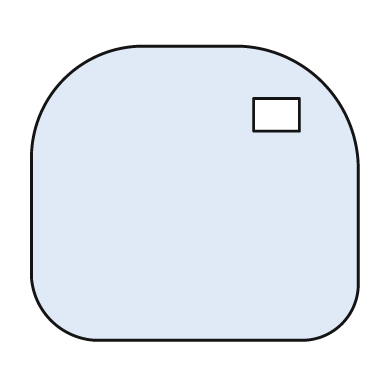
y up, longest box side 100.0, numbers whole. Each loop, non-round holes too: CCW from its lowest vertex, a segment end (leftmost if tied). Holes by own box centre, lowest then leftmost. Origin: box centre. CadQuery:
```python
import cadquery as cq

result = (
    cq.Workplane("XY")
    .moveTo(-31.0, -45.0)
    .lineTo(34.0, -45.0)
    .threePointArc((45.0, -40.0), (50.0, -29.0))
    .lineTo(50.0, 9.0)
    .threePointArc((39.0, 34.0), (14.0, 45.0))
    .lineTo(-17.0, 45.0)
    .threePointArc((-40.0, 35.0), (-50.0, 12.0))
    .lineTo(-50.0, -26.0)
    .threePointArc((-44.0, -39.0), (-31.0, -45.0))
    .close()
    .moveTo(18.0, 19.0)
    .lineTo(32.0, 19.0)
    .lineTo(32.0, 29.0)
    .lineTo(18.0, 29.0)
    .close()
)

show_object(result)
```